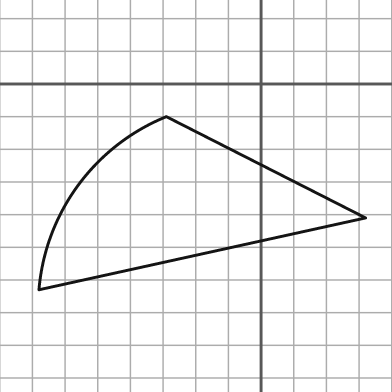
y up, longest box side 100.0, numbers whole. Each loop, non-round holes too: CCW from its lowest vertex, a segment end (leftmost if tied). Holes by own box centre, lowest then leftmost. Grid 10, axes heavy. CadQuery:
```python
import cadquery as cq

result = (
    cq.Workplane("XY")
    .moveTo(-68.0, -63.0)
    .lineTo(32.0, -41.0)
    .lineTo(-29.0, -10.0)
    .threePointArc((-56.0, -31.0), (-68.0, -63.0))
    .close()
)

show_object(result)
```